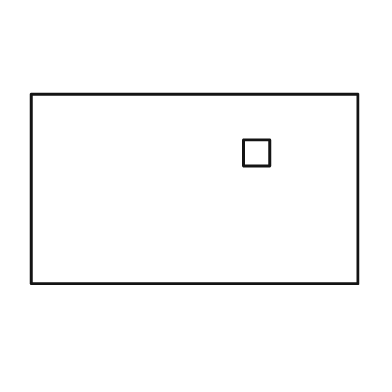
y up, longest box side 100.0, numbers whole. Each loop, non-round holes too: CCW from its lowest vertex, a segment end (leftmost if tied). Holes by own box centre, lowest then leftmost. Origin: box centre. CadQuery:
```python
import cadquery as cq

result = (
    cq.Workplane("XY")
    .moveTo(-50.0, -29.0)
    .lineTo(50.0, -29.0)
    .lineTo(50.0, 29.0)
    .lineTo(-50.0, 29.0)
    .close()
    .moveTo(15.0, 7.0)
    .lineTo(23.0, 7.0)
    .lineTo(23.0, 15.0)
    .lineTo(15.0, 15.0)
    .close()
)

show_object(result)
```